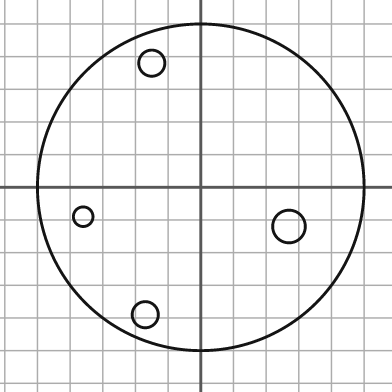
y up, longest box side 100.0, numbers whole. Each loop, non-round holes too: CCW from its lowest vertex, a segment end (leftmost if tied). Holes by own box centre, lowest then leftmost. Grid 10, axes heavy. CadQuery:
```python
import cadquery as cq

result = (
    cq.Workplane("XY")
    .moveTo(0.0, 0.0)
    .circle(50.0)
    .moveTo(-17.0, -39.0)
    .circle(4.0)
    .moveTo(27.0, -12.0)
    .circle(5.0)
    .moveTo(-36.0, -9.0)
    .circle(3.0)
    .moveTo(-15.0, 38.0)
    .circle(4.0)
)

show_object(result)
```